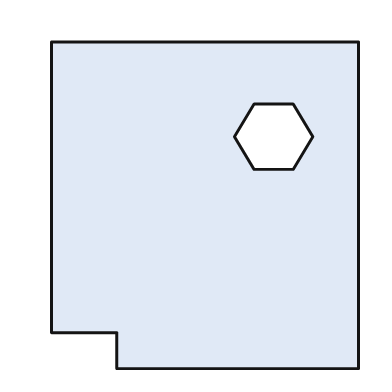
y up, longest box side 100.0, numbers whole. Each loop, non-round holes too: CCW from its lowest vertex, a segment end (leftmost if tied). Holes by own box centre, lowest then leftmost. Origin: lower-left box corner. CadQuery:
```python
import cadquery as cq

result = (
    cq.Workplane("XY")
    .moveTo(20.0, 0.0)
    .lineTo(94.0, 0.0)
    .lineTo(94.0, 100.0)
    .lineTo(0.0, 100.0)
    .lineTo(0.0, 11.0)
    .lineTo(20.0, 11.0)
    .close()
    .moveTo(62.0, 61.0)
    .lineTo(74.0, 61.0)
    .lineTo(80.0, 71.0)
    .lineTo(74.0, 81.0)
    .lineTo(62.0, 81.0)
    .lineTo(56.0, 71.0)
    .close()
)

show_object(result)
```